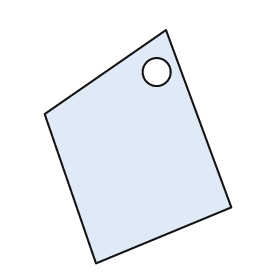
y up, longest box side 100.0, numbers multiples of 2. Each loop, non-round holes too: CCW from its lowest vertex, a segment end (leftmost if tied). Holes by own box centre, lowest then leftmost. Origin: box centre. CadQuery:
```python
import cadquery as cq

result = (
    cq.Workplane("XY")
    .moveTo(-18.0, -50.0)
    .lineTo(40.0, -26.0)
    .lineTo(12.0, 50.0)
    .lineTo(-40.0, 14.0)
    .close()
    .moveTo(8.0, 32.0)
    .circle(6.0)
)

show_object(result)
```